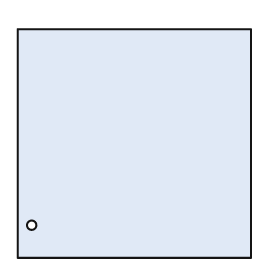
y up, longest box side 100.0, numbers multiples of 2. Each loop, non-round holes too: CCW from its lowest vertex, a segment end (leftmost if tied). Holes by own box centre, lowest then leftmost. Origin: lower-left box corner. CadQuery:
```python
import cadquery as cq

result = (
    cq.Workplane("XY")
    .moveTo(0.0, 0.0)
    .lineTo(100.0, 0.0)
    .lineTo(100.0, 98.0)
    .lineTo(0.0, 98.0)
    .close()
    .moveTo(6.0, 14.0)
    .circle(2.0)
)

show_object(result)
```